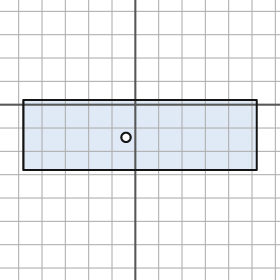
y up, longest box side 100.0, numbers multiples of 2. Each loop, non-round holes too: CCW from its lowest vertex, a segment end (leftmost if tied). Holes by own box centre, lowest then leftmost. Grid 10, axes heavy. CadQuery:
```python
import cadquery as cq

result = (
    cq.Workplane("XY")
    .moveTo(-48.0, -28.0)
    .lineTo(52.0, -28.0)
    .lineTo(52.0, 2.0)
    .lineTo(-48.0, 2.0)
    .close()
    .moveTo(-4.0, -14.0)
    .circle(2.0)
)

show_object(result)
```